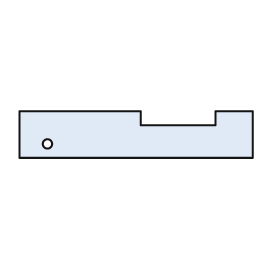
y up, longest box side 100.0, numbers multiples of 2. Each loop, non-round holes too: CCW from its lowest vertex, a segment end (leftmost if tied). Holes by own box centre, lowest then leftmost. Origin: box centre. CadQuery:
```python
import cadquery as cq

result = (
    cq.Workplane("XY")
    .moveTo(-50.0, -10.0)
    .lineTo(50.0, -10.0)
    .lineTo(50.0, 10.0)
    .lineTo(34.0, 10.0)
    .lineTo(34.0, 4.0)
    .lineTo(2.0, 4.0)
    .lineTo(2.0, 10.0)
    .lineTo(-50.0, 10.0)
    .close()
    .moveTo(-38.0, -4.0)
    .circle(2.0)
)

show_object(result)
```